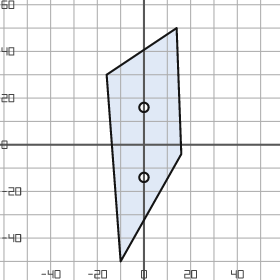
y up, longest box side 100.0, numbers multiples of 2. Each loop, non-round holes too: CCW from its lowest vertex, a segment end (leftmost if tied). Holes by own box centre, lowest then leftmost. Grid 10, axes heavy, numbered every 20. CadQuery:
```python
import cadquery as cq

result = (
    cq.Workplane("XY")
    .moveTo(-10.0, -50.0)
    .lineTo(16.0, -4.0)
    .lineTo(14.0, 50.0)
    .lineTo(-16.0, 30.0)
    .close()
    .moveTo(0.0, -14.0)
    .circle(2.0)
    .moveTo(0.0, 16.0)
    .circle(2.0)
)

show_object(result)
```